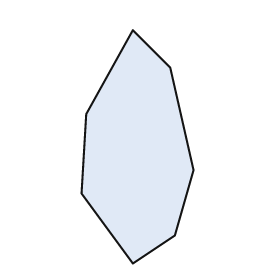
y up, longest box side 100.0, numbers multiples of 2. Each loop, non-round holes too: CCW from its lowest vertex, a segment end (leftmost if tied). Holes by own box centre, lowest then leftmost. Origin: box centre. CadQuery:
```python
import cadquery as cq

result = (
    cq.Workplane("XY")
    .moveTo(-2.0, -50.0)
    .lineTo(16.0, -38.0)
    .lineTo(24.0, -10.0)
    .lineTo(14.0, 34.0)
    .lineTo(-2.0, 50.0)
    .lineTo(-22.0, 14.0)
    .lineTo(-24.0, -20.0)
    .close()
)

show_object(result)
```